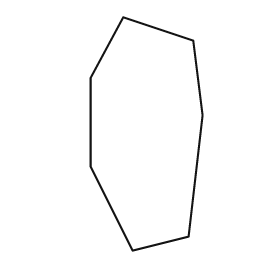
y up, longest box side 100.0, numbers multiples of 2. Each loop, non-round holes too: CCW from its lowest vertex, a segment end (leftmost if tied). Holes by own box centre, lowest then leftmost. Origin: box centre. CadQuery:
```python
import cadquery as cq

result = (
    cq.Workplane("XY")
    .moveTo(-6.0, -50.0)
    .lineTo(18.0, -44.0)
    .lineTo(24.0, 8.0)
    .lineTo(20.0, 40.0)
    .lineTo(-10.0, 50.0)
    .lineTo(-24.0, 24.0)
    .lineTo(-24.0, -14.0)
    .close()
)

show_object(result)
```